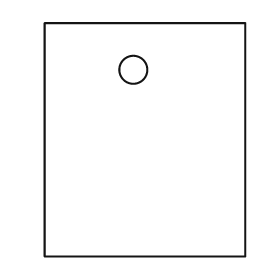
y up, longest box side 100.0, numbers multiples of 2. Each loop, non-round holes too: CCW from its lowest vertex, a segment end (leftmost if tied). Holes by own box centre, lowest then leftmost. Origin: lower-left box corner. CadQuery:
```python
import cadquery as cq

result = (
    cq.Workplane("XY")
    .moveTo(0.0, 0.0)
    .lineTo(86.0, 0.0)
    .lineTo(86.0, 100.0)
    .lineTo(0.0, 100.0)
    .close()
    .moveTo(38.0, 80.0)
    .circle(6.0)
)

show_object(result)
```